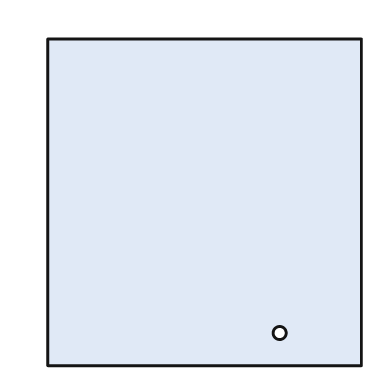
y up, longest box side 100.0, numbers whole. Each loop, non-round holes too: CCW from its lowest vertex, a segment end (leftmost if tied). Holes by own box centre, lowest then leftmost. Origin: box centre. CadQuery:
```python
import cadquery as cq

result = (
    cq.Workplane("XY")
    .moveTo(-48.0, -50.0)
    .lineTo(48.0, -50.0)
    .lineTo(48.0, 50.0)
    .lineTo(-48.0, 50.0)
    .close()
    .moveTo(23.0, -40.0)
    .circle(2.0)
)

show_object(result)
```